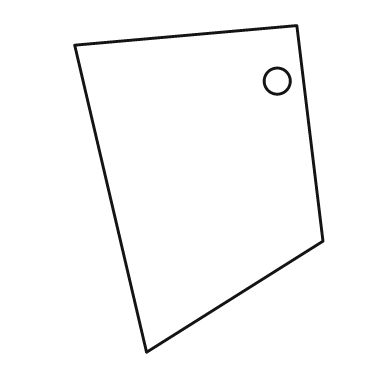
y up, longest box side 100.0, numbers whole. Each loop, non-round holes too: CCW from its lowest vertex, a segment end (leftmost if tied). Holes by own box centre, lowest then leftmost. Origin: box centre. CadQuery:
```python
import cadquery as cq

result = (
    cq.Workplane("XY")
    .moveTo(-16.0, -50.0)
    .lineTo(38.0, -16.0)
    .lineTo(30.0, 50.0)
    .lineTo(-38.0, 44.0)
    .close()
    .moveTo(24.0, 33.0)
    .circle(4.0)
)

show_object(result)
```